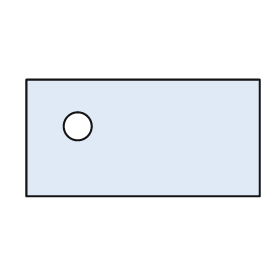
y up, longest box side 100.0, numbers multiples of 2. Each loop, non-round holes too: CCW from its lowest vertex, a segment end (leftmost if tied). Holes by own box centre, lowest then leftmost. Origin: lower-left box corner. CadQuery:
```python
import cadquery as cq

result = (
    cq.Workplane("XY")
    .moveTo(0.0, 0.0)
    .lineTo(100.0, 0.0)
    .lineTo(100.0, 50.0)
    .lineTo(0.0, 50.0)
    .close()
    .moveTo(22.0, 30.0)
    .circle(6.0)
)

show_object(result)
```